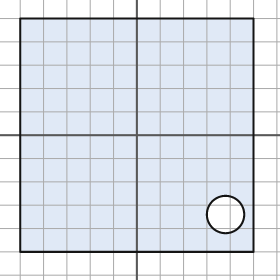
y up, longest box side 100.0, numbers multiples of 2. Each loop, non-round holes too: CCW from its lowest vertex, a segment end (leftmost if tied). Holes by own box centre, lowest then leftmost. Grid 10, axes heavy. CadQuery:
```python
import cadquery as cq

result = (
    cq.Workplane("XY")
    .moveTo(-50.0, -50.0)
    .lineTo(50.0, -50.0)
    .lineTo(50.0, 50.0)
    .lineTo(-50.0, 50.0)
    .close()
    .moveTo(38.0, -34.0)
    .circle(8.0)
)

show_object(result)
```